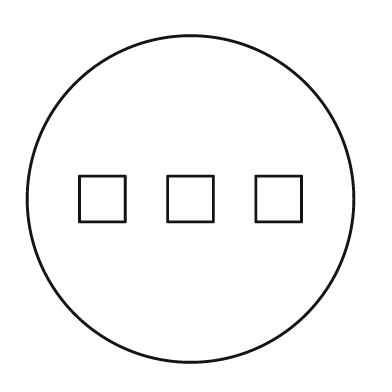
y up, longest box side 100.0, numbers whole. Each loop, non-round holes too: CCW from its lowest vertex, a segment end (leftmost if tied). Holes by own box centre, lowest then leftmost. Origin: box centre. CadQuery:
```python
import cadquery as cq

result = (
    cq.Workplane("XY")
    .moveTo(0.0, 0.0)
    .circle(50.0)
    .moveTo(-34.0, -7.0)
    .lineTo(-20.0, -7.0)
    .lineTo(-20.0, 7.0)
    .lineTo(-34.0, 7.0)
    .close()
    .moveTo(-7.0, -7.0)
    .lineTo(7.0, -7.0)
    .lineTo(7.0, 7.0)
    .lineTo(-7.0, 7.0)
    .close()
    .moveTo(20.0, -7.0)
    .lineTo(34.0, -7.0)
    .lineTo(34.0, 7.0)
    .lineTo(20.0, 7.0)
    .close()
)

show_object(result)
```